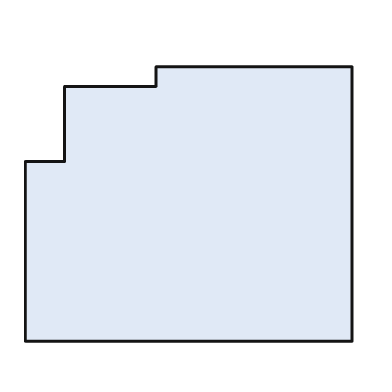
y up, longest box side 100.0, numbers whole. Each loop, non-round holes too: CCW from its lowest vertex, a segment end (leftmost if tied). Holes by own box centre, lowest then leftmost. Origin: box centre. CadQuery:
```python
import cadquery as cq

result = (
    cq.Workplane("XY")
    .moveTo(-50.0, -42.0)
    .lineTo(50.0, -42.0)
    .lineTo(50.0, 42.0)
    .lineTo(-10.0, 42.0)
    .lineTo(-10.0, 36.0)
    .lineTo(-38.0, 36.0)
    .lineTo(-38.0, 13.0)
    .lineTo(-50.0, 13.0)
    .close()
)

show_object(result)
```